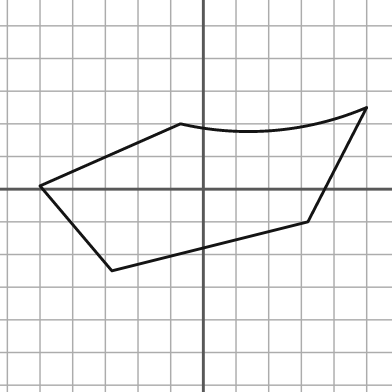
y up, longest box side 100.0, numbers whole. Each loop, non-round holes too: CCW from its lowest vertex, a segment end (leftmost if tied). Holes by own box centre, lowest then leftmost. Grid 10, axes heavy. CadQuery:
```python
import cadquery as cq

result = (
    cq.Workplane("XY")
    .moveTo(-28.0, -25.0)
    .lineTo(32.0, -10.0)
    .lineTo(50.0, 25.0)
    .threePointArc((22.0, 18.0), (-7.0, 20.0))
    .lineTo(-50.0, 1.0)
    .close()
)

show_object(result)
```